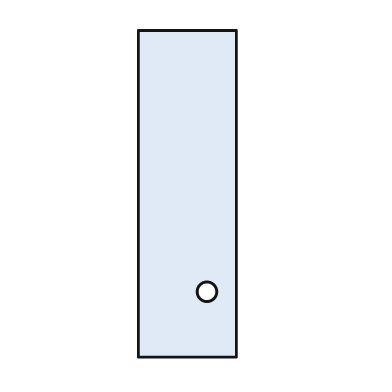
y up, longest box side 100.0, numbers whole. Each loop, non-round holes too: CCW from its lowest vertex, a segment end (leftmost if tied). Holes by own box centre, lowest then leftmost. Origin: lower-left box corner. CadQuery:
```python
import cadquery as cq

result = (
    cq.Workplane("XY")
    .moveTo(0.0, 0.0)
    .lineTo(30.0, 0.0)
    .lineTo(30.0, 100.0)
    .lineTo(0.0, 100.0)
    .close()
    .moveTo(21.0, 20.0)
    .circle(3.0)
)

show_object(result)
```